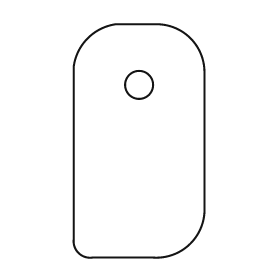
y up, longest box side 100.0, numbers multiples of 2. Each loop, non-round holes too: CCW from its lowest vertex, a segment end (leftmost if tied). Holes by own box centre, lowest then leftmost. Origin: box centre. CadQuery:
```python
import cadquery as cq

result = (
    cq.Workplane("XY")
    .moveTo(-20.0, -50.0)
    .lineTo(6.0, -50.0)
    .threePointArc((22.0, -44.0), (28.0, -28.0))
    .lineTo(28.0, 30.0)
    .threePointArc((22.0, 44.0), (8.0, 50.0))
    .lineTo(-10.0, 50.0)
    .threePointArc((-22.0, 44.0), (-28.0, 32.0))
    .lineTo(-28.0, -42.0)
    .threePointArc((-26.0, -48.0), (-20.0, -50.0))
    .close()
    .moveTo(0.0, 24.0)
    .circle(6.0)
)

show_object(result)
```